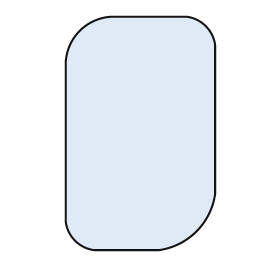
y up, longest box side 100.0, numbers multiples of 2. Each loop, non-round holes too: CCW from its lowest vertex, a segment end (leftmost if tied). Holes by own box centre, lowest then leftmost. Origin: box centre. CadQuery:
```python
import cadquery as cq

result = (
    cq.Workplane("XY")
    .moveTo(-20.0, -50.0)
    .lineTo(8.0, -50.0)
    .threePointArc((24.0, -42.0), (32.0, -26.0))
    .lineTo(32.0, 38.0)
    .threePointArc((28.0, 46.0), (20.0, 50.0))
    .lineTo(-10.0, 50.0)
    .threePointArc((-26.0, 44.0), (-32.0, 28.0))
    .lineTo(-32.0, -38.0)
    .threePointArc((-28.0, -46.0), (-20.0, -50.0))
    .close()
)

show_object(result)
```